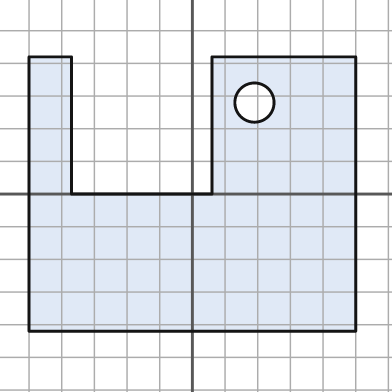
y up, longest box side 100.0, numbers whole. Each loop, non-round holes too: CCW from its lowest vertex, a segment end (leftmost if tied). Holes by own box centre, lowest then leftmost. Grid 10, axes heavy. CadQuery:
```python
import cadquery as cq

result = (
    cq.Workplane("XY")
    .moveTo(-50.0, -42.0)
    .lineTo(50.0, -42.0)
    .lineTo(50.0, 42.0)
    .lineTo(6.0, 42.0)
    .lineTo(6.0, 0.0)
    .lineTo(-37.0, 0.0)
    .lineTo(-37.0, 42.0)
    .lineTo(-50.0, 42.0)
    .close()
    .moveTo(19.0, 28.0)
    .circle(6.0)
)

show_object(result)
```